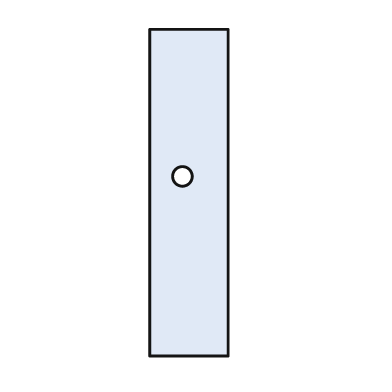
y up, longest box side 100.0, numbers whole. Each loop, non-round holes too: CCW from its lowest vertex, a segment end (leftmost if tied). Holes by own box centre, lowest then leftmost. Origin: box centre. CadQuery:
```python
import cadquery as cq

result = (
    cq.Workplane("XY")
    .moveTo(-12.0, -50.0)
    .lineTo(12.0, -50.0)
    .lineTo(12.0, 50.0)
    .lineTo(-12.0, 50.0)
    .close()
    .moveTo(-2.0, 5.0)
    .circle(3.0)
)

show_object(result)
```